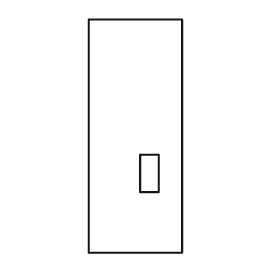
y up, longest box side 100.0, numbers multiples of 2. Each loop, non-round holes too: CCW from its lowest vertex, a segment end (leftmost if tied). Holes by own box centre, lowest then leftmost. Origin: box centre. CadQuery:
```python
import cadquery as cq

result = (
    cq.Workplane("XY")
    .moveTo(-20.0, -50.0)
    .lineTo(20.0, -50.0)
    .lineTo(20.0, 50.0)
    .lineTo(-20.0, 50.0)
    .close()
    .moveTo(2.0, -24.0)
    .lineTo(10.0, -24.0)
    .lineTo(10.0, -8.0)
    .lineTo(2.0, -8.0)
    .close()
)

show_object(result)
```